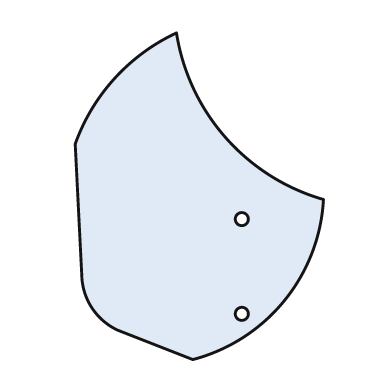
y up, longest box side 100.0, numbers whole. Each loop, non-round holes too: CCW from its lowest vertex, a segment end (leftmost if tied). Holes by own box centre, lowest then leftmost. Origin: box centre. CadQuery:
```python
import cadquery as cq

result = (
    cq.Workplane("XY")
    .moveTo(-2.0, -50.0)
    .threePointArc((26.0, -32.0), (38.0, -1.0))
    .threePointArc((8.0, 18.0), (-7.0, 50.0))
    .threePointArc((-26.0, 36.0), (-38.0, 16.0))
    .lineTo(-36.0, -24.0)
    .threePointArc((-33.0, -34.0), (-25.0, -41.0))
    .close()
    .moveTo(13.0, -36.0)
    .circle(2.0)
    .moveTo(13.0, -7.0)
    .circle(2.0)
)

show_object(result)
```